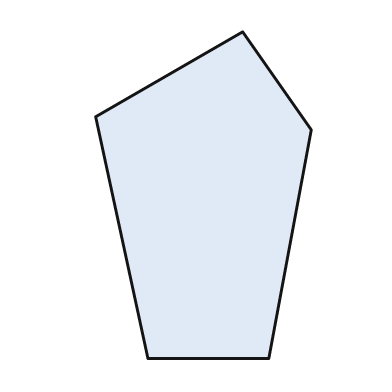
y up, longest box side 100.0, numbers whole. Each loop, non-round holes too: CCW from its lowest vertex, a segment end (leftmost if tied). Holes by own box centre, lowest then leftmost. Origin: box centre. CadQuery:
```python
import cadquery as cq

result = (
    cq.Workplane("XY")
    .moveTo(-17.0, -50.0)
    .lineTo(20.0, -50.0)
    .lineTo(33.0, 20.0)
    .lineTo(12.0, 50.0)
    .lineTo(-33.0, 24.0)
    .close()
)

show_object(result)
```